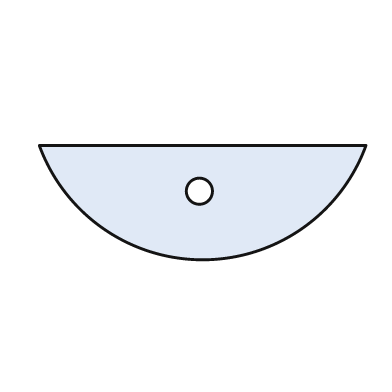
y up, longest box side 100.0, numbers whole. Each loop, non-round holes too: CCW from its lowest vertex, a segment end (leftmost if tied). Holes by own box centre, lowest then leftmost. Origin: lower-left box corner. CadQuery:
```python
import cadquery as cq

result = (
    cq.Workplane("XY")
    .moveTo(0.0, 35.0)
    .threePointArc((50.0, 0.0), (100.0, 35.0))
    .close()
    .moveTo(49.0, 21.0)
    .circle(4.0)
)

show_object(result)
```